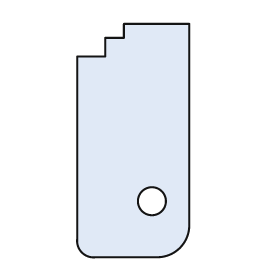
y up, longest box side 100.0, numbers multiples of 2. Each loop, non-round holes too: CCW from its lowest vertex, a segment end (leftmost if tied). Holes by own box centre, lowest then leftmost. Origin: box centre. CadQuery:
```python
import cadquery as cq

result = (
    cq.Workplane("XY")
    .moveTo(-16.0, -50.0)
    .lineTo(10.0, -50.0)
    .threePointArc((20.0, -46.0), (24.0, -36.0))
    .lineTo(24.0, 50.0)
    .lineTo(-4.0, 50.0)
    .lineTo(-4.0, 44.0)
    .lineTo(-12.0, 44.0)
    .lineTo(-12.0, 36.0)
    .lineTo(-24.0, 36.0)
    .lineTo(-24.0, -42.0)
    .threePointArc((-22.0, -48.0), (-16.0, -50.0))
    .close()
    .moveTo(8.0, -26.0)
    .circle(6.0)
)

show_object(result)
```